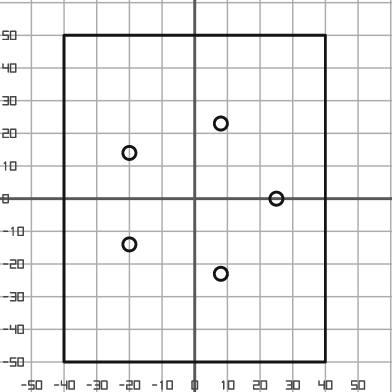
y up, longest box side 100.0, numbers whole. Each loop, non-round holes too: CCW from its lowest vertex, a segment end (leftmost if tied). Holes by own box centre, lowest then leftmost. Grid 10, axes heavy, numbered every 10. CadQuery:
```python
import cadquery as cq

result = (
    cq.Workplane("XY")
    .moveTo(-40.0, -50.0)
    .lineTo(40.0, -50.0)
    .lineTo(40.0, 50.0)
    .lineTo(-40.0, 50.0)
    .close()
    .moveTo(8.0, -23.0)
    .circle(2.0)
    .moveTo(-20.0, -14.0)
    .circle(2.0)
    .moveTo(25.0, 0.0)
    .circle(2.0)
    .moveTo(-20.0, 14.0)
    .circle(2.0)
    .moveTo(8.0, 23.0)
    .circle(2.0)
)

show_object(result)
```